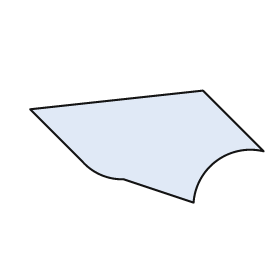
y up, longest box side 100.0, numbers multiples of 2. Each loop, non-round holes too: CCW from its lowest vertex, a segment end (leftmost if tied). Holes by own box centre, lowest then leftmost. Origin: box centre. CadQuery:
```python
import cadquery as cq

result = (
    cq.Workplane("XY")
    .moveTo(20.0, -24.0)
    .threePointArc((30.0, -6.0), (50.0, -2.0))
    .lineTo(24.0, 24.0)
    .lineTo(-50.0, 16.0)
    .lineTo(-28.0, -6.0)
    .threePointArc((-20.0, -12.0), (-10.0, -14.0))
    .close()
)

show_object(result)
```